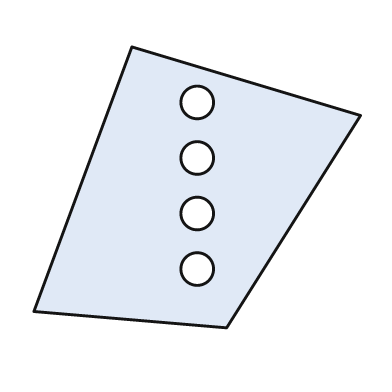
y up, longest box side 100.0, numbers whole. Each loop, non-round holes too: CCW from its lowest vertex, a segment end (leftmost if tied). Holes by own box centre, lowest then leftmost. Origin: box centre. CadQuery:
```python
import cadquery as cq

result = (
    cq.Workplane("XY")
    .moveTo(9.0, -43.0)
    .lineTo(50.0, 22.0)
    .lineTo(-20.0, 43.0)
    .lineTo(-50.0, -38.0)
    .close()
    .moveTo(0.0, -25.0)
    .circle(5.0)
    .moveTo(0.0, -8.0)
    .circle(5.0)
    .moveTo(0.0, 9.0)
    .circle(5.0)
    .moveTo(0.0, 26.0)
    .circle(5.0)
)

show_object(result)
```